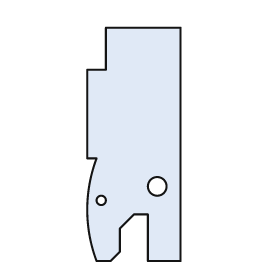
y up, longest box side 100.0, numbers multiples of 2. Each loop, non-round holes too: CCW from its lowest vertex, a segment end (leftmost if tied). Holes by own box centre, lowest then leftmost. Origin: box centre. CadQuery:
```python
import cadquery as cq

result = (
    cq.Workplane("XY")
    .moveTo(-16.0, -50.0)
    .lineTo(-10.0, -50.0)
    .lineTo(-6.0, -46.0)
    .lineTo(-6.0, -36.0)
    .lineTo(0.0, -30.0)
    .lineTo(6.0, -30.0)
    .lineTo(6.0, -50.0)
    .lineTo(20.0, -50.0)
    .lineTo(20.0, 50.0)
    .lineTo(-12.0, 50.0)
    .lineTo(-12.0, 32.0)
    .lineTo(-20.0, 32.0)
    .lineTo(-20.0, -6.0)
    .lineTo(-16.0, -6.0)
    .threePointArc((-20.0, -28.0), (-16.0, -50.0))
    .close()
    .moveTo(-14.0, -24.0)
    .circle(2.0)
    .moveTo(10.0, -18.0)
    .circle(4.0)
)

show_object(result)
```